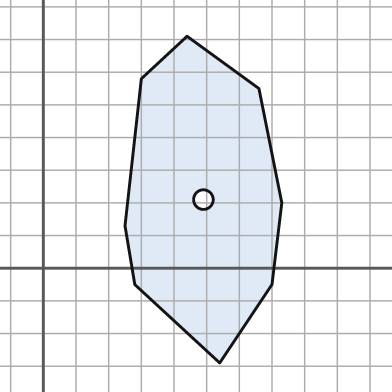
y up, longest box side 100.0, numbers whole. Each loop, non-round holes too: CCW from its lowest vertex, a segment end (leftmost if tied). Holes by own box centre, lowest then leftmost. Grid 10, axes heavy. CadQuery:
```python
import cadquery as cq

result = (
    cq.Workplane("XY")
    .moveTo(54.0, -29.0)
    .lineTo(70.0, -5.0)
    .lineTo(73.0, 20.0)
    .lineTo(66.0, 55.0)
    .lineTo(44.0, 71.0)
    .lineTo(30.0, 58.0)
    .lineTo(25.0, 13.0)
    .lineTo(28.0, -5.0)
    .close()
    .moveTo(49.0, 21.0)
    .circle(3.0)
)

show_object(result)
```